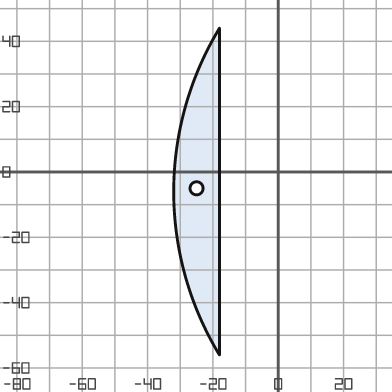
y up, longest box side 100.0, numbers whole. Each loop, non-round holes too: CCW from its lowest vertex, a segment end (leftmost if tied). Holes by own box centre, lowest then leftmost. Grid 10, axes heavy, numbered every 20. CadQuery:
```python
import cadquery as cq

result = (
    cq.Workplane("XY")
    .moveTo(-18.0, -56.0)
    .lineTo(-18.0, 44.0)
    .threePointArc((-32.0, -6.0), (-18.0, -56.0))
    .close()
    .moveTo(-25.0, -5.0)
    .circle(2.0)
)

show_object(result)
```